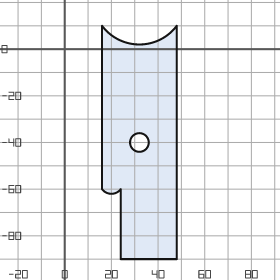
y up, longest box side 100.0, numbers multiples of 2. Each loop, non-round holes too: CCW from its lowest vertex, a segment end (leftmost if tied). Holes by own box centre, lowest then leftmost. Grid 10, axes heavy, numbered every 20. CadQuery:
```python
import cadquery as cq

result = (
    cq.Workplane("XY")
    .moveTo(24.0, -90.0)
    .lineTo(48.0, -90.0)
    .lineTo(48.0, 10.0)
    .threePointArc((32.0, 2.0), (16.0, 10.0))
    .lineTo(16.0, -60.0)
    .threePointArc((20.0, -62.0), (24.0, -60.0))
    .close()
    .moveTo(32.0, -40.0)
    .circle(4.0)
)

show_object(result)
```